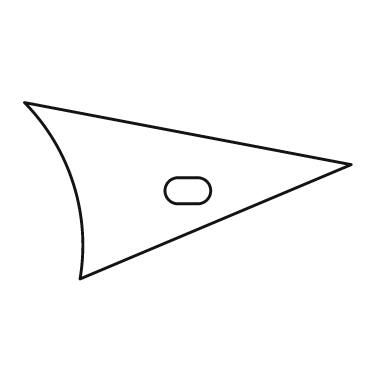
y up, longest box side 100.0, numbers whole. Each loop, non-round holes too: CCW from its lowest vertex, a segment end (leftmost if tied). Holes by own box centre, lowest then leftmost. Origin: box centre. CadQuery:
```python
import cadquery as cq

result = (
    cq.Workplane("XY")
    .moveTo(-33.0, -27.0)
    .lineTo(50.0, 8.0)
    .lineTo(-50.0, 27.0)
    .threePointArc((-35.0, 2.0), (-33.0, -27.0))
    .close()
    .moveTo(-3.0, -4.0)
    .lineTo(3.0, -4.0)
    .threePointArc((7.0, 0.0), (3.0, 4.0))
    .lineTo(-3.0, 4.0)
    .threePointArc((-7.0, 0.0), (-3.0, -4.0))
    .close()
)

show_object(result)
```